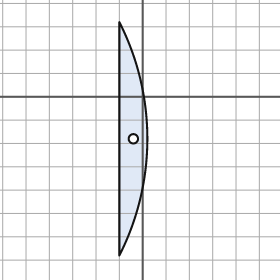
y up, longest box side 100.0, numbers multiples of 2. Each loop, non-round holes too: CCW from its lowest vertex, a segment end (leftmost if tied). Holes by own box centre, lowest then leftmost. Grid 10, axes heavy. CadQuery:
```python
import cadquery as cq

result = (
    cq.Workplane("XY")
    .moveTo(-10.0, -68.0)
    .threePointArc((2.0, -18.0), (-10.0, 32.0))
    .close()
    .moveTo(-4.0, -18.0)
    .circle(2.0)
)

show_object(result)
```